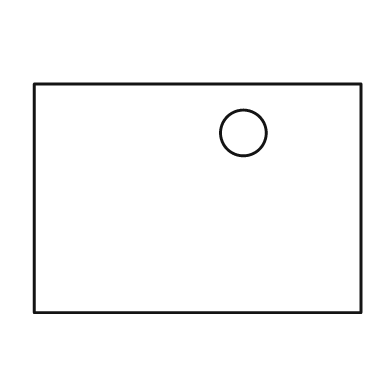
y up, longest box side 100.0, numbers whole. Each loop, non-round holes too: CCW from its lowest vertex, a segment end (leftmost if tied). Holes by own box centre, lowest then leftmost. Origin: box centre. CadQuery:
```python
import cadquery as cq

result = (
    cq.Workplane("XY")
    .moveTo(-50.0, -35.0)
    .lineTo(50.0, -35.0)
    .lineTo(50.0, 35.0)
    .lineTo(-50.0, 35.0)
    .close()
    .moveTo(14.0, 20.0)
    .circle(7.0)
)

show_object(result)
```